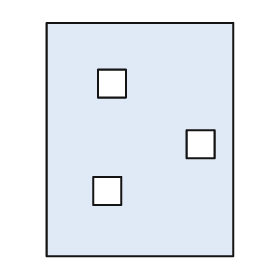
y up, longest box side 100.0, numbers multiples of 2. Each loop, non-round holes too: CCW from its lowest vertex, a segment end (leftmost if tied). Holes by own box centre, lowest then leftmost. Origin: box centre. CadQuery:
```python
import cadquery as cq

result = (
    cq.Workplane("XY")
    .moveTo(-40.0, -50.0)
    .lineTo(40.0, -50.0)
    .lineTo(40.0, 50.0)
    .lineTo(-40.0, 50.0)
    .close()
    .moveTo(-20.0, -28.0)
    .lineTo(-8.0, -28.0)
    .lineTo(-8.0, -16.0)
    .lineTo(-20.0, -16.0)
    .close()
    .moveTo(20.0, -8.0)
    .lineTo(32.0, -8.0)
    .lineTo(32.0, 4.0)
    .lineTo(20.0, 4.0)
    .close()
    .moveTo(-18.0, 18.0)
    .lineTo(-6.0, 18.0)
    .lineTo(-6.0, 30.0)
    .lineTo(-18.0, 30.0)
    .close()
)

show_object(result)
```